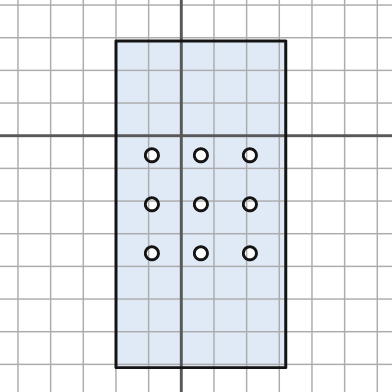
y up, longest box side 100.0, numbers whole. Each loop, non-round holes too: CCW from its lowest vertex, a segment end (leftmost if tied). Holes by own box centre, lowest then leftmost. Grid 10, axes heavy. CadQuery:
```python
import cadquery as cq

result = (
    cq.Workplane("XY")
    .moveTo(-20.0, -71.0)
    .lineTo(32.0, -71.0)
    .lineTo(32.0, 29.0)
    .lineTo(-20.0, 29.0)
    .close()
    .moveTo(-9.0, -36.0)
    .circle(2.0)
    .moveTo(6.0, -36.0)
    .circle(2.0)
    .moveTo(21.0, -36.0)
    .circle(2.0)
    .moveTo(-9.0, -21.0)
    .circle(2.0)
    .moveTo(6.0, -21.0)
    .circle(2.0)
    .moveTo(21.0, -21.0)
    .circle(2.0)
    .moveTo(-9.0, -6.0)
    .circle(2.0)
    .moveTo(6.0, -6.0)
    .circle(2.0)
    .moveTo(21.0, -6.0)
    .circle(2.0)
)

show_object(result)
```